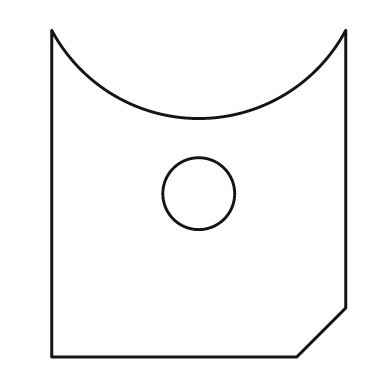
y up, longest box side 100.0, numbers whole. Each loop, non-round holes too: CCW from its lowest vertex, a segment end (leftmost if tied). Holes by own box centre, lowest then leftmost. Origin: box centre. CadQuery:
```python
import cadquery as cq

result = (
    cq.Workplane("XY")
    .moveTo(-45.0, -50.0)
    .lineTo(30.0, -50.0)
    .lineTo(45.0, -35.0)
    .lineTo(45.0, 50.0)
    .threePointArc((0.0, 23.0), (-45.0, 50.0))
    .close()
    .moveTo(0.0, 0.0)
    .circle(11.0)
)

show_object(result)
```